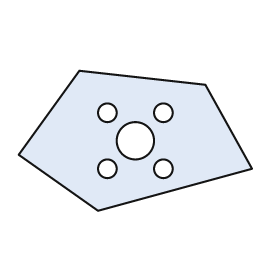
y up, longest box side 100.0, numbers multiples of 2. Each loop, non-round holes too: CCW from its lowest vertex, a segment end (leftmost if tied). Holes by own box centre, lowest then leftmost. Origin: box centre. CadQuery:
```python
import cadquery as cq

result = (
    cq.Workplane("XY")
    .moveTo(-16.0, -30.0)
    .lineTo(50.0, -12.0)
    .lineTo(30.0, 24.0)
    .lineTo(-24.0, 30.0)
    .lineTo(-50.0, -6.0)
    .close()
    .moveTo(-12.0, -12.0)
    .circle(4.0)
    .moveTo(12.0, -12.0)
    .circle(4.0)
    .moveTo(0.0, 0.0)
    .circle(8.0)
    .moveTo(-12.0, 12.0)
    .circle(4.0)
    .moveTo(12.0, 12.0)
    .circle(4.0)
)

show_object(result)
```